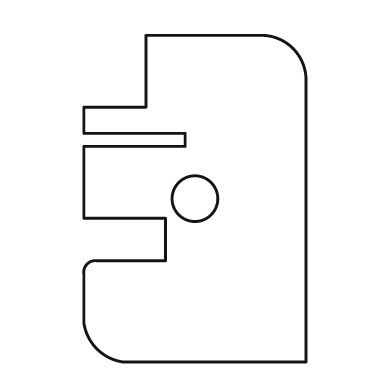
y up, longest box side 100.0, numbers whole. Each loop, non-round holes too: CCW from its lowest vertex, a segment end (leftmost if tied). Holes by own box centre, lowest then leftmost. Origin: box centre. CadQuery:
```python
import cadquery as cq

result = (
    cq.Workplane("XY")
    .moveTo(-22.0, -50.0)
    .lineTo(34.0, -50.0)
    .lineTo(34.0, 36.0)
    .threePointArc((30.0, 46.0), (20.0, 50.0))
    .lineTo(-15.0, 50.0)
    .lineTo(-15.0, 28.0)
    .lineTo(-34.0, 28.0)
    .lineTo(-34.0, 20.0)
    .lineTo(-3.0, 20.0)
    .lineTo(-3.0, 16.0)
    .lineTo(-34.0, 16.0)
    .lineTo(-34.0, -6.0)
    .lineTo(-9.0, -6.0)
    .lineTo(-9.0, -19.0)
    .lineTo(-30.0, -19.0)
    .threePointArc((-33.0, -20.0), (-34.0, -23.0))
    .lineTo(-34.0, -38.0)
    .threePointArc((-30.0, -46.0), (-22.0, -50.0))
    .close()
    .moveTo(0.0, 0.0)
    .circle(7.0)
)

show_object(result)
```